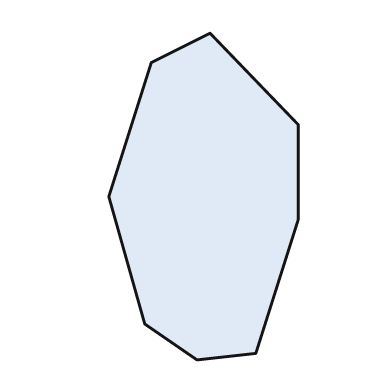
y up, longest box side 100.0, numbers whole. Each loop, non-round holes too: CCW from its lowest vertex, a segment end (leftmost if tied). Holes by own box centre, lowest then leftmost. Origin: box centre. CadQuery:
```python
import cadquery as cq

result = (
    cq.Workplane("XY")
    .moveTo(-2.0, -50.0)
    .lineTo(16.0, -48.0)
    .lineTo(29.0, -7.0)
    .lineTo(29.0, 22.0)
    .lineTo(2.0, 50.0)
    .lineTo(-16.0, 41.0)
    .lineTo(-29.0, 0.0)
    .lineTo(-18.0, -39.0)
    .close()
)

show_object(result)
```